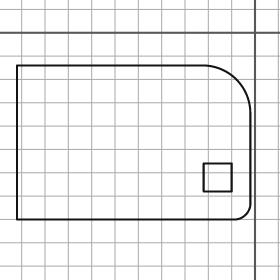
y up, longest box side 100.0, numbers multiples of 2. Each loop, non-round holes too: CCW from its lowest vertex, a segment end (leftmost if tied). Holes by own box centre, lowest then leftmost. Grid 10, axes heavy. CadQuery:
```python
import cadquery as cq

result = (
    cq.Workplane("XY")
    .moveTo(-102.0, -80.0)
    .lineTo(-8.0, -80.0)
    .threePointArc((-4.0, -78.0), (-2.0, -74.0))
    .lineTo(-2.0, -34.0)
    .threePointArc((-8.0, -20.0), (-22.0, -14.0))
    .lineTo(-102.0, -14.0)
    .close()
    .moveTo(-22.0, -68.0)
    .lineTo(-10.0, -68.0)
    .lineTo(-10.0, -56.0)
    .lineTo(-22.0, -56.0)
    .close()
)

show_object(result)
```